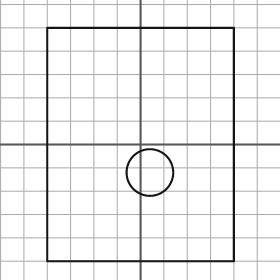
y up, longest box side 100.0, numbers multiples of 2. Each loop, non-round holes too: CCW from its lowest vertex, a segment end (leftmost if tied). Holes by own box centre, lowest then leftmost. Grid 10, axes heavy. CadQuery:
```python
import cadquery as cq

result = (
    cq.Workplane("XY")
    .moveTo(-40.0, -50.0)
    .lineTo(40.0, -50.0)
    .lineTo(40.0, 50.0)
    .lineTo(-40.0, 50.0)
    .close()
    .moveTo(4.0, -12.0)
    .circle(10.0)
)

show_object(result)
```